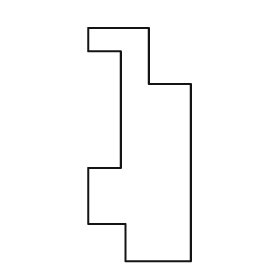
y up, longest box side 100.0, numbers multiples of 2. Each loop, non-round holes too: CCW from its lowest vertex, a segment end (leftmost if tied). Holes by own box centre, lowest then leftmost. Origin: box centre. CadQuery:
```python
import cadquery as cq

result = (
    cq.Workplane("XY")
    .moveTo(-6.0, -50.0)
    .lineTo(22.0, -50.0)
    .lineTo(22.0, 26.0)
    .lineTo(4.0, 26.0)
    .lineTo(4.0, 50.0)
    .lineTo(-22.0, 50.0)
    .lineTo(-22.0, 40.0)
    .lineTo(-8.0, 40.0)
    .lineTo(-8.0, -10.0)
    .lineTo(-22.0, -10.0)
    .lineTo(-22.0, -34.0)
    .lineTo(-6.0, -34.0)
    .close()
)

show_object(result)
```